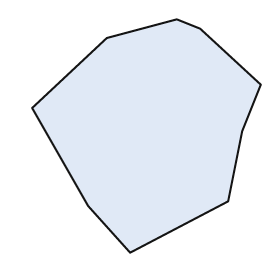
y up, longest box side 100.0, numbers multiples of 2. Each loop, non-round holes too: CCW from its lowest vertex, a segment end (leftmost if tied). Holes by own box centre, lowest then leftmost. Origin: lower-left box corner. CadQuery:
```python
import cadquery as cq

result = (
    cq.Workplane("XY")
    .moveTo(42.0, 0.0)
    .lineTo(84.0, 22.0)
    .lineTo(90.0, 52.0)
    .lineTo(98.0, 72.0)
    .lineTo(72.0, 96.0)
    .lineTo(62.0, 100.0)
    .lineTo(32.0, 92.0)
    .lineTo(0.0, 62.0)
    .lineTo(24.0, 20.0)
    .close()
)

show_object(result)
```